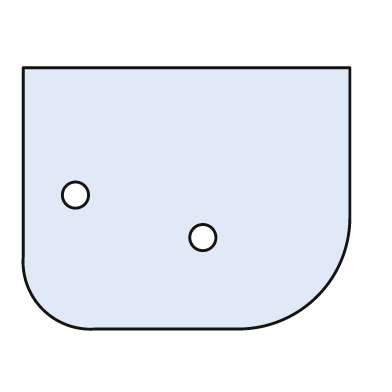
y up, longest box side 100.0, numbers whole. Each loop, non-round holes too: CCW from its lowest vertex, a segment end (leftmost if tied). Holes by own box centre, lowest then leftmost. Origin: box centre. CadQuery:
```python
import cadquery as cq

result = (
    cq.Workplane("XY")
    .moveTo(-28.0, -40.0)
    .lineTo(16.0, -40.0)
    .threePointArc((40.0, -30.0), (50.0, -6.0))
    .lineTo(50.0, 40.0)
    .lineTo(-50.0, 40.0)
    .lineTo(-50.0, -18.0)
    .threePointArc((-44.0, -34.0), (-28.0, -40.0))
    .close()
    .moveTo(5.0, -12.0)
    .circle(4.0)
    .moveTo(-34.0, 1.0)
    .circle(4.0)
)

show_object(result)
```